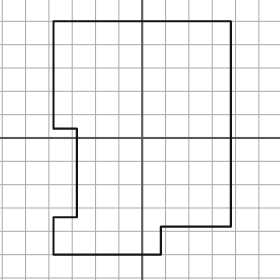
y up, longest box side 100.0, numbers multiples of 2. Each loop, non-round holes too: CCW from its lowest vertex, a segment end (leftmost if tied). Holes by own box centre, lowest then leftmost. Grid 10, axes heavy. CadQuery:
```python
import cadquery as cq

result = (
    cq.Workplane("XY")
    .moveTo(-38.0, -50.0)
    .lineTo(8.0, -50.0)
    .lineTo(8.0, -38.0)
    .lineTo(38.0, -38.0)
    .lineTo(38.0, 50.0)
    .lineTo(-38.0, 50.0)
    .lineTo(-38.0, 4.0)
    .lineTo(-28.0, 4.0)
    .lineTo(-28.0, -34.0)
    .lineTo(-38.0, -34.0)
    .close()
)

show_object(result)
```